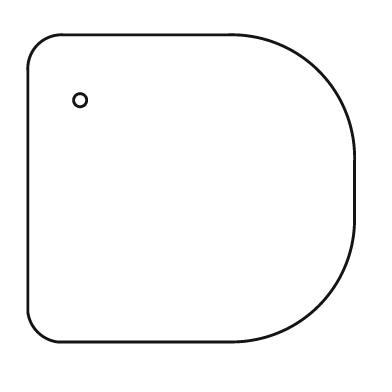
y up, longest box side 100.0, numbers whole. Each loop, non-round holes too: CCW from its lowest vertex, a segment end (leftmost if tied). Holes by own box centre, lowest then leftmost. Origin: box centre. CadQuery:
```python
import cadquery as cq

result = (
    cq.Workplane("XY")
    .moveTo(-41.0, -47.0)
    .lineTo(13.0, -47.0)
    .threePointArc((39.0, -36.0), (50.0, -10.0))
    .lineTo(50.0, 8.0)
    .threePointArc((39.0, 36.0), (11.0, 47.0))
    .lineTo(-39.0, 47.0)
    .threePointArc((-47.0, 44.0), (-50.0, 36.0))
    .lineTo(-50.0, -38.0)
    .threePointArc((-47.0, -44.0), (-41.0, -47.0))
    .close()
    .moveTo(-34.0, 27.0)
    .circle(2.0)
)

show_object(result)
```